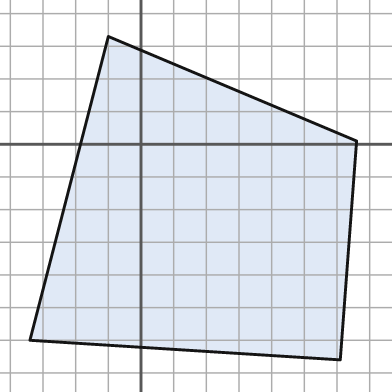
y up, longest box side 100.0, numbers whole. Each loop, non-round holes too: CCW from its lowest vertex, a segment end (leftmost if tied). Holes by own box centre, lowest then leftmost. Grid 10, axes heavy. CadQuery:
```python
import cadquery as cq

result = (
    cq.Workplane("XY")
    .moveTo(61.0, -66.0)
    .lineTo(66.0, 1.0)
    .lineTo(-10.0, 33.0)
    .lineTo(-34.0, -60.0)
    .close()
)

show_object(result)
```